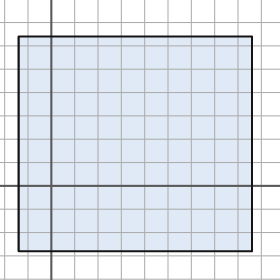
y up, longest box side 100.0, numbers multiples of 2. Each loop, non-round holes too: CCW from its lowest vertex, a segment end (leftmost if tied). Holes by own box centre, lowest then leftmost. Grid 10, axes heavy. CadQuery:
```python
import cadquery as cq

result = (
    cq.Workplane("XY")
    .moveTo(-14.0, -28.0)
    .lineTo(86.0, -28.0)
    .lineTo(86.0, 64.0)
    .lineTo(-14.0, 64.0)
    .close()
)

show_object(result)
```